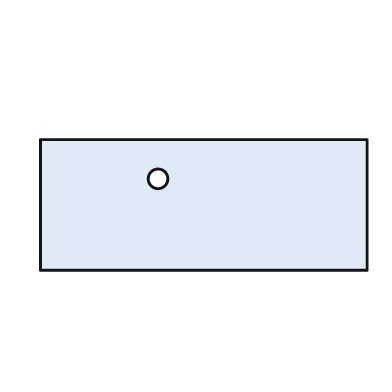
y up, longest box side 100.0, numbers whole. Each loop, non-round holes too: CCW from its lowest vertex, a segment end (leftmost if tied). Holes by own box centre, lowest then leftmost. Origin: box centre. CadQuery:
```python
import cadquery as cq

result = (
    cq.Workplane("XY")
    .moveTo(-50.0, -20.0)
    .lineTo(50.0, -20.0)
    .lineTo(50.0, 20.0)
    .lineTo(-50.0, 20.0)
    .close()
    .moveTo(-14.0, 8.0)
    .circle(3.0)
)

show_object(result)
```